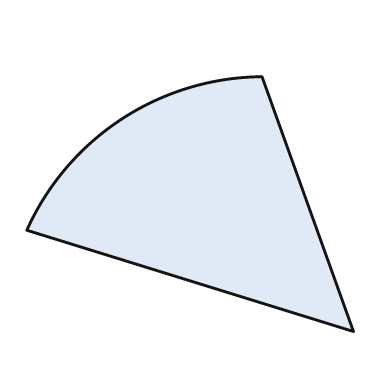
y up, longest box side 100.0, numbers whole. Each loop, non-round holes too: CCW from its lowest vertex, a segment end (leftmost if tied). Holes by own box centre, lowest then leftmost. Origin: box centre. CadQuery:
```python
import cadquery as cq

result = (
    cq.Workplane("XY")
    .moveTo(50.0, -39.0)
    .lineTo(22.0, 39.0)
    .threePointArc((-21.0, 26.0), (-50.0, -8.0))
    .close()
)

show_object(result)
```